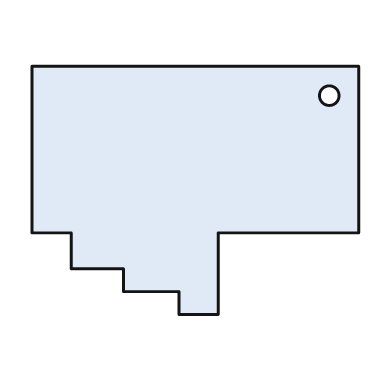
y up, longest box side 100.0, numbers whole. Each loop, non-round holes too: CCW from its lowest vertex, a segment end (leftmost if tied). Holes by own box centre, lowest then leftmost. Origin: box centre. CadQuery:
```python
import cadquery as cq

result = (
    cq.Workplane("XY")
    .moveTo(-5.0, -38.0)
    .lineTo(7.0, -38.0)
    .lineTo(7.0, -13.0)
    .lineTo(50.0, -13.0)
    .lineTo(50.0, 38.0)
    .lineTo(-50.0, 38.0)
    .lineTo(-50.0, -13.0)
    .lineTo(-38.0, -13.0)
    .lineTo(-38.0, -24.0)
    .lineTo(-22.0, -24.0)
    .lineTo(-22.0, -31.0)
    .lineTo(-5.0, -31.0)
    .close()
    .moveTo(41.0, 29.0)
    .circle(3.0)
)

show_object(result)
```